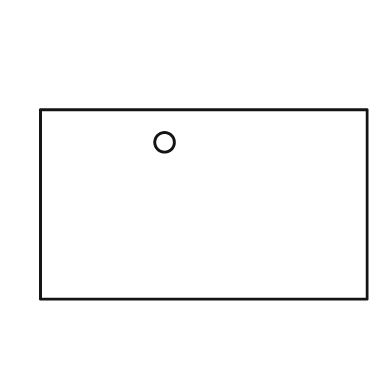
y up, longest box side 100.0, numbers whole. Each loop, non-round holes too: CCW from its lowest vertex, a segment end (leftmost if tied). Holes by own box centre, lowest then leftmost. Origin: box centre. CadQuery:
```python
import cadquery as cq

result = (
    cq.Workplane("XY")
    .moveTo(-50.0, -29.0)
    .lineTo(50.0, -29.0)
    .lineTo(50.0, 29.0)
    .lineTo(-50.0, 29.0)
    .close()
    .moveTo(-12.0, 19.0)
    .circle(3.0)
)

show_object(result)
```